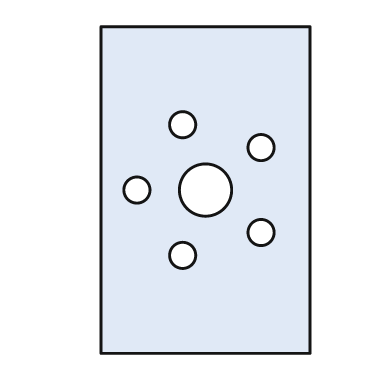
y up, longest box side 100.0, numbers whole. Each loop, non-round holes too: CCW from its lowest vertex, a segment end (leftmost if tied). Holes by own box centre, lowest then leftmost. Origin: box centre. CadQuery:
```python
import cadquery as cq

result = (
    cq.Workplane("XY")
    .moveTo(-32.0, -50.0)
    .lineTo(32.0, -50.0)
    .lineTo(32.0, 50.0)
    .lineTo(-32.0, 50.0)
    .close()
    .moveTo(-7.0, -20.0)
    .circle(4.0)
    .moveTo(17.0, -13.0)
    .circle(4.0)
    .moveTo(-21.0, 0.0)
    .circle(4.0)
    .moveTo(0.0, 0.0)
    .circle(8.0)
    .moveTo(17.0, 13.0)
    .circle(4.0)
    .moveTo(-7.0, 20.0)
    .circle(4.0)
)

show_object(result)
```